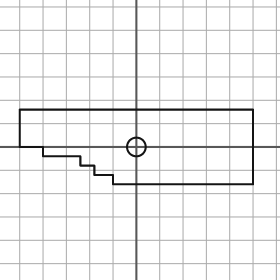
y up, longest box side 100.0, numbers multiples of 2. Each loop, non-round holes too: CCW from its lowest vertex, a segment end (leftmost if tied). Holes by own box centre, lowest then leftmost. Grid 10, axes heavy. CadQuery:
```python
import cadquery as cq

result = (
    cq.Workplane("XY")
    .moveTo(-10.0, -16.0)
    .lineTo(50.0, -16.0)
    .lineTo(50.0, 16.0)
    .lineTo(-50.0, 16.0)
    .lineTo(-50.0, 0.0)
    .lineTo(-40.0, 0.0)
    .lineTo(-40.0, -4.0)
    .lineTo(-24.0, -4.0)
    .lineTo(-24.0, -8.0)
    .lineTo(-18.0, -8.0)
    .lineTo(-18.0, -12.0)
    .lineTo(-10.0, -12.0)
    .close()
    .moveTo(0.0, 0.0)
    .circle(4.0)
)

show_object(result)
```